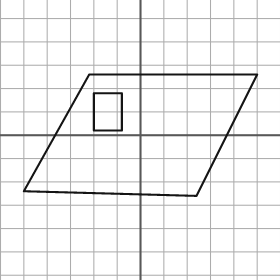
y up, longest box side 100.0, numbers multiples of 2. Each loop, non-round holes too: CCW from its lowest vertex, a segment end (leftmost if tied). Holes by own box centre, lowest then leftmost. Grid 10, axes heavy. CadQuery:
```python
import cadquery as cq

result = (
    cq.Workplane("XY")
    .moveTo(24.0, -26.0)
    .lineTo(50.0, 26.0)
    .lineTo(-22.0, 26.0)
    .lineTo(-50.0, -24.0)
    .close()
    .moveTo(-20.0, 2.0)
    .lineTo(-8.0, 2.0)
    .lineTo(-8.0, 18.0)
    .lineTo(-20.0, 18.0)
    .close()
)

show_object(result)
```